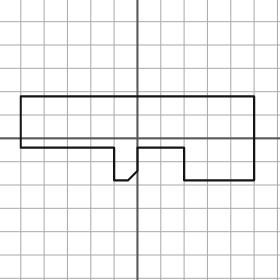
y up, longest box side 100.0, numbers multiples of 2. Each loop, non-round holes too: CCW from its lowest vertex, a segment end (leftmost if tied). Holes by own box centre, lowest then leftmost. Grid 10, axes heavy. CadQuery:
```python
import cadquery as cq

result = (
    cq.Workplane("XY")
    .moveTo(-10.0, -18.0)
    .lineTo(-4.0, -18.0)
    .lineTo(0.0, -14.0)
    .lineTo(0.0, -4.0)
    .lineTo(20.0, -4.0)
    .lineTo(20.0, -18.0)
    .lineTo(50.0, -18.0)
    .lineTo(50.0, 18.0)
    .lineTo(-50.0, 18.0)
    .lineTo(-50.0, -4.0)
    .lineTo(-10.0, -4.0)
    .close()
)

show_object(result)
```